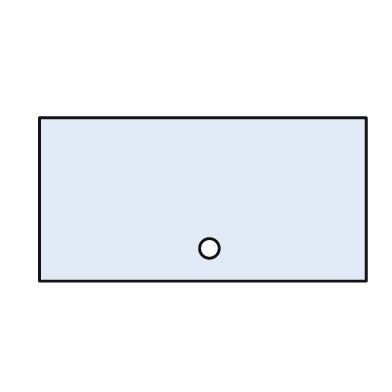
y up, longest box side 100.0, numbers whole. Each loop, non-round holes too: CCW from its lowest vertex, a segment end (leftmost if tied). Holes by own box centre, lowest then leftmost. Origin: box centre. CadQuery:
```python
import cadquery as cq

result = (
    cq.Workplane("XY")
    .moveTo(-50.0, -25.0)
    .lineTo(50.0, -25.0)
    .lineTo(50.0, 25.0)
    .lineTo(-50.0, 25.0)
    .close()
    .moveTo(2.0, -15.0)
    .circle(3.0)
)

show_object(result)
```